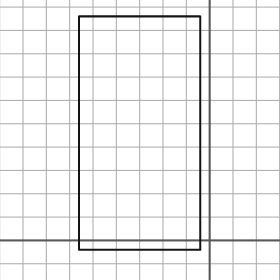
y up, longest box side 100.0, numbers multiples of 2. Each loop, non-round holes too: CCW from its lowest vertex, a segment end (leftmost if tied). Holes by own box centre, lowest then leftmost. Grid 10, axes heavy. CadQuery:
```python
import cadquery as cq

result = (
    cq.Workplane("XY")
    .moveTo(-56.0, -4.0)
    .lineTo(-4.0, -4.0)
    .lineTo(-4.0, 96.0)
    .lineTo(-56.0, 96.0)
    .close()
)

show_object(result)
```